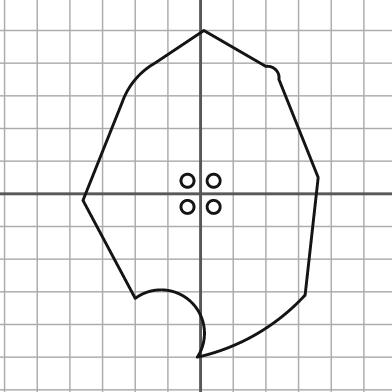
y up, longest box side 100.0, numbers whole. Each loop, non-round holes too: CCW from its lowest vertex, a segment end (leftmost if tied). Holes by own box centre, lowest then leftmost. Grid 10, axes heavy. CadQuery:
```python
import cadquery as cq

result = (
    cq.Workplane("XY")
    .moveTo(-1.0, -50.0)
    .threePointArc((17.0, -43.0), (32.0, -31.0))
    .lineTo(36.0, 5.0)
    .lineTo(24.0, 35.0)
    .threePointArc((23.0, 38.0), (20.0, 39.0))
    .lineTo(1.0, 50.0)
    .lineTo(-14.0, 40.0)
    .threePointArc((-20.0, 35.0), (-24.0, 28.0))
    .lineTo(-36.0, -2.0)
    .lineTo(-20.0, -32.0)
    .threePointArc((-3.0, -33.0), (-1.0, -50.0))
    .close()
    .moveTo(-4.0, -4.0)
    .circle(2.0)
    .moveTo(4.0, -4.0)
    .circle(2.0)
    .moveTo(-4.0, 4.0)
    .circle(2.0)
    .moveTo(4.0, 4.0)
    .circle(2.0)
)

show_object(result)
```